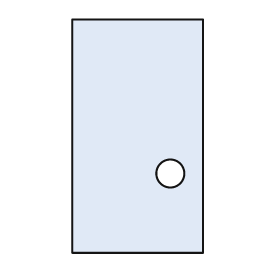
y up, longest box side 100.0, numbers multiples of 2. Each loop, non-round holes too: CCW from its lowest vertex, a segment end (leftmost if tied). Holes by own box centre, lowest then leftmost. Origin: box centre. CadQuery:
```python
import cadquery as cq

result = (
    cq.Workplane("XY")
    .moveTo(-28.0, -50.0)
    .lineTo(28.0, -50.0)
    .lineTo(28.0, 50.0)
    .lineTo(-28.0, 50.0)
    .close()
    .moveTo(14.0, -16.0)
    .circle(6.0)
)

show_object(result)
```